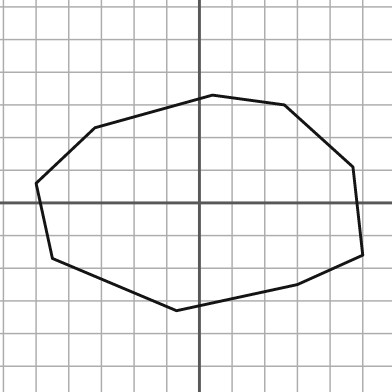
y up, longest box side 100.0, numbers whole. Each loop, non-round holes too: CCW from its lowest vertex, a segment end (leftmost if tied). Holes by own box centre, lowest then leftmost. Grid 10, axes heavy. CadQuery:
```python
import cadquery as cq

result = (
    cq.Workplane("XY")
    .moveTo(-7.0, -33.0)
    .lineTo(30.0, -25.0)
    .lineTo(50.0, -16.0)
    .lineTo(47.0, 11.0)
    .lineTo(26.0, 30.0)
    .lineTo(4.0, 33.0)
    .lineTo(-32.0, 23.0)
    .lineTo(-50.0, 6.0)
    .lineTo(-45.0, -17.0)
    .close()
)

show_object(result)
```